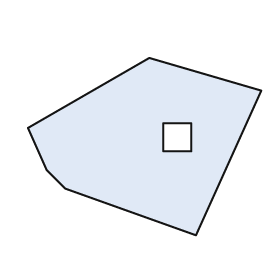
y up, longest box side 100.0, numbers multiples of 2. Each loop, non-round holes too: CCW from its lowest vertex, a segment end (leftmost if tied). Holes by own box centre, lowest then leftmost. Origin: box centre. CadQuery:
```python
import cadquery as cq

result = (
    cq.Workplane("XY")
    .moveTo(22.0, -38.0)
    .lineTo(50.0, 24.0)
    .lineTo(2.0, 38.0)
    .lineTo(-50.0, 8.0)
    .lineTo(-42.0, -10.0)
    .lineTo(-34.0, -18.0)
    .close()
    .moveTo(8.0, -2.0)
    .lineTo(20.0, -2.0)
    .lineTo(20.0, 10.0)
    .lineTo(8.0, 10.0)
    .close()
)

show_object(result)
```